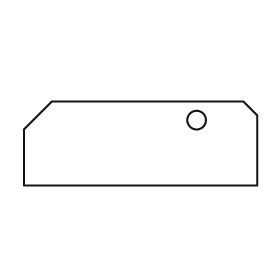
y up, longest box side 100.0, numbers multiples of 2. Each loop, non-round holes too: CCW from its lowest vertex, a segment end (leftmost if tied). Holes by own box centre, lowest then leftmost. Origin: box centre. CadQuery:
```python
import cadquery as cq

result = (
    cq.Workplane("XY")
    .moveTo(-50.0, -18.0)
    .lineTo(50.0, -18.0)
    .lineTo(50.0, 12.0)
    .lineTo(44.0, 18.0)
    .lineTo(-38.0, 18.0)
    .lineTo(-50.0, 6.0)
    .close()
    .moveTo(24.0, 10.0)
    .circle(4.0)
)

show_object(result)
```